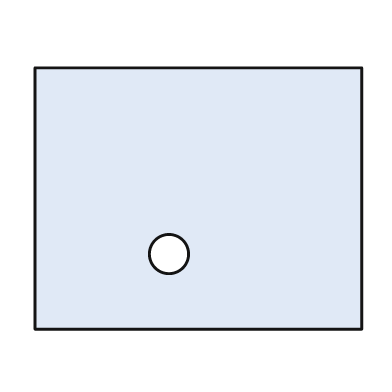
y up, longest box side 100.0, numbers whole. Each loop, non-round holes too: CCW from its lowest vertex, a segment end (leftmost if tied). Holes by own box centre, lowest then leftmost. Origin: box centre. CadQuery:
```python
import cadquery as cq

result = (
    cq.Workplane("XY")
    .moveTo(-50.0, -40.0)
    .lineTo(50.0, -40.0)
    .lineTo(50.0, 40.0)
    .lineTo(-50.0, 40.0)
    .close()
    .moveTo(-9.0, -17.0)
    .circle(6.0)
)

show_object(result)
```